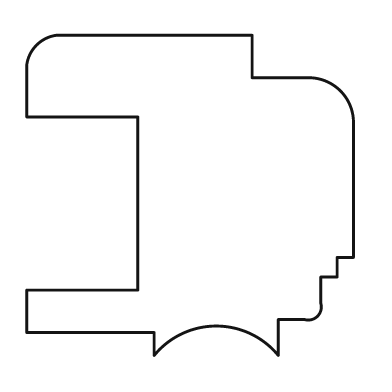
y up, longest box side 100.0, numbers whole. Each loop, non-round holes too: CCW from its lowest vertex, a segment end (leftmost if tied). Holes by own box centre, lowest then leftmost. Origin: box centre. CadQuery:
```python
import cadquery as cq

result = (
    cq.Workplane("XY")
    .moveTo(-11.0, -49.0)
    .threePointArc((8.0, -40.0), (27.0, -49.0))
    .lineTo(27.0, -38.0)
    .lineTo(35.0, -38.0)
    .threePointArc((39.0, -37.0), (40.0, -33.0))
    .lineTo(40.0, -25.0)
    .lineTo(45.0, -25.0)
    .lineTo(45.0, -19.0)
    .lineTo(50.0, -19.0)
    .lineTo(50.0, 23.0)
    .threePointArc((46.0, 32.0), (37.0, 36.0))
    .lineTo(19.0, 36.0)
    .lineTo(19.0, 49.0)
    .lineTo(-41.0, 49.0)
    .threePointArc((-47.0, 46.0), (-50.0, 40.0))
    .lineTo(-50.0, 24.0)
    .lineTo(-16.0, 24.0)
    .lineTo(-16.0, -29.0)
    .lineTo(-50.0, -29.0)
    .lineTo(-50.0, -42.0)
    .lineTo(-11.0, -42.0)
    .close()
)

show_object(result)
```